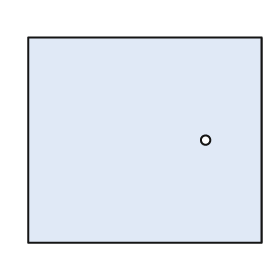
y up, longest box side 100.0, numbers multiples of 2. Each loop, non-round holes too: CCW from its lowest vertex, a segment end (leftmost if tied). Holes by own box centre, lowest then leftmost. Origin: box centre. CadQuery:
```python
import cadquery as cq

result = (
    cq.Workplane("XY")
    .moveTo(-50.0, -44.0)
    .lineTo(50.0, -44.0)
    .lineTo(50.0, 44.0)
    .lineTo(-50.0, 44.0)
    .close()
    .moveTo(26.0, 0.0)
    .circle(2.0)
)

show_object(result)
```